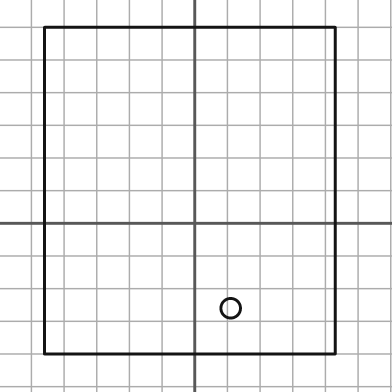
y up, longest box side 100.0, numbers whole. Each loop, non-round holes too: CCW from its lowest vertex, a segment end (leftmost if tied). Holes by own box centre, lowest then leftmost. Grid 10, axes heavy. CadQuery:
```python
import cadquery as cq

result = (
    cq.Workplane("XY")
    .moveTo(-46.0, -40.0)
    .lineTo(43.0, -40.0)
    .lineTo(43.0, 60.0)
    .lineTo(-46.0, 60.0)
    .close()
    .moveTo(11.0, -26.0)
    .circle(3.0)
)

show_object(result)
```